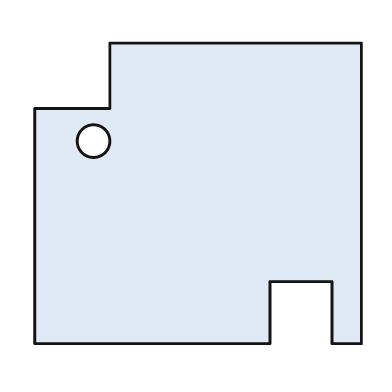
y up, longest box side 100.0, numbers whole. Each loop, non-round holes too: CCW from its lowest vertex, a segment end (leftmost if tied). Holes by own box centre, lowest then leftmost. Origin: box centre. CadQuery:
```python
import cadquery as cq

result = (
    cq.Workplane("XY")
    .moveTo(-50.0, -46.0)
    .lineTo(22.0, -46.0)
    .lineTo(22.0, -27.0)
    .lineTo(41.0, -27.0)
    .lineTo(41.0, -46.0)
    .lineTo(50.0, -46.0)
    .lineTo(50.0, 46.0)
    .lineTo(-27.0, 46.0)
    .lineTo(-27.0, 26.0)
    .lineTo(-50.0, 26.0)
    .close()
    .moveTo(-32.0, 16.0)
    .circle(5.0)
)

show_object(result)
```